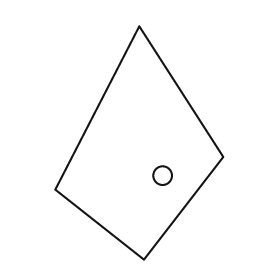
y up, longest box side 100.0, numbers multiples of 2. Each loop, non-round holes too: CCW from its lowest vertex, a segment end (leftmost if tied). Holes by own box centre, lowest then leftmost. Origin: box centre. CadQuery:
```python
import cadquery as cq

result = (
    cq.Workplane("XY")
    .moveTo(2.0, -50.0)
    .lineTo(36.0, -6.0)
    .lineTo(0.0, 50.0)
    .lineTo(-36.0, -20.0)
    .close()
    .moveTo(10.0, -14.0)
    .circle(4.0)
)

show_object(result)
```